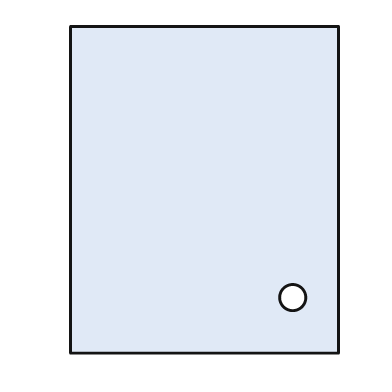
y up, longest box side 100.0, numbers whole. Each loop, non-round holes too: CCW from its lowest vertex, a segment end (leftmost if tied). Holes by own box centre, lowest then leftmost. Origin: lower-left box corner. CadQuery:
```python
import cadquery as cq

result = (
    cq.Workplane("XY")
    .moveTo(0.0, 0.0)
    .lineTo(82.0, 0.0)
    .lineTo(82.0, 100.0)
    .lineTo(0.0, 100.0)
    .close()
    .moveTo(68.0, 17.0)
    .circle(4.0)
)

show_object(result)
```